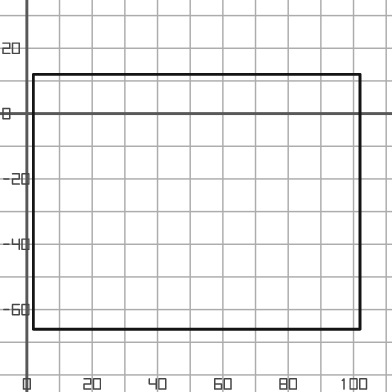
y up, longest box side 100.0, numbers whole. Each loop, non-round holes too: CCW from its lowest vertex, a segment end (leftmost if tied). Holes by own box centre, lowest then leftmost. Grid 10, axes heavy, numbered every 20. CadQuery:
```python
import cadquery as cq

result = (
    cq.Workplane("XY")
    .moveTo(2.0, -66.0)
    .lineTo(102.0, -66.0)
    .lineTo(102.0, 12.0)
    .lineTo(2.0, 12.0)
    .close()
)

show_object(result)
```